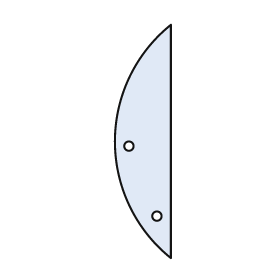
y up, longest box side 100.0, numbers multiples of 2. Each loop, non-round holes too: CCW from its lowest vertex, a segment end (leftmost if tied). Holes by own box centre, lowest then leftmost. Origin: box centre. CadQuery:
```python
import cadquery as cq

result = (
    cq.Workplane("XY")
    .moveTo(12.0, -50.0)
    .lineTo(12.0, 50.0)
    .threePointArc((-12.0, 0.0), (12.0, -50.0))
    .close()
    .moveTo(6.0, -32.0)
    .circle(2.0)
    .moveTo(-6.0, -2.0)
    .circle(2.0)
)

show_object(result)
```